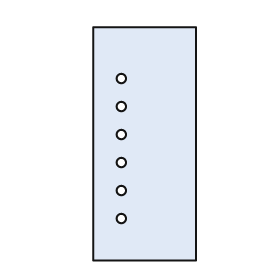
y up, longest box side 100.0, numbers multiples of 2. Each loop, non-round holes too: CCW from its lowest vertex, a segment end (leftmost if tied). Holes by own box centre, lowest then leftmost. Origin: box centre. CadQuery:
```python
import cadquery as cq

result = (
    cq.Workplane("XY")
    .moveTo(-22.0, -50.0)
    .lineTo(22.0, -50.0)
    .lineTo(22.0, 50.0)
    .lineTo(-22.0, 50.0)
    .close()
    .moveTo(-10.0, -32.0)
    .circle(2.0)
    .moveTo(-10.0, -20.0)
    .circle(2.0)
    .moveTo(-10.0, -8.0)
    .circle(2.0)
    .moveTo(-10.0, 4.0)
    .circle(2.0)
    .moveTo(-10.0, 16.0)
    .circle(2.0)
    .moveTo(-10.0, 28.0)
    .circle(2.0)
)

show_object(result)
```